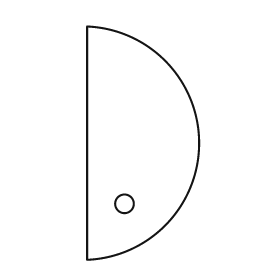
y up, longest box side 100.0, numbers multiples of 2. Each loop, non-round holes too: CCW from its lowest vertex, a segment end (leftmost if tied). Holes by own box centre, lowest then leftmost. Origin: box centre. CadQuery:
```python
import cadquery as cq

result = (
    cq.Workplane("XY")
    .moveTo(-24.0, -50.0)
    .threePointArc((24.0, 0.0), (-24.0, 50.0))
    .close()
    .moveTo(-8.0, -26.0)
    .circle(4.0)
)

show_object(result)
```